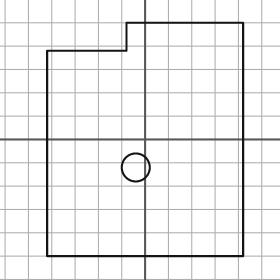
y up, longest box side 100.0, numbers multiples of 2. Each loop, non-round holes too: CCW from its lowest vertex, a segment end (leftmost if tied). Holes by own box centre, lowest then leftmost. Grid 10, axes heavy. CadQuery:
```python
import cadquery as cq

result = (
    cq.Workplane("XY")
    .moveTo(-42.0, -50.0)
    .lineTo(42.0, -50.0)
    .lineTo(42.0, 50.0)
    .lineTo(-8.0, 50.0)
    .lineTo(-8.0, 38.0)
    .lineTo(-42.0, 38.0)
    .close()
    .moveTo(-4.0, -12.0)
    .circle(6.0)
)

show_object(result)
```